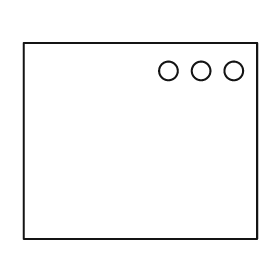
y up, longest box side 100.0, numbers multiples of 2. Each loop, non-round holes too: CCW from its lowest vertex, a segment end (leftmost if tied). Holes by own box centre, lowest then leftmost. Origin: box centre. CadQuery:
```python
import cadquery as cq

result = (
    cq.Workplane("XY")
    .moveTo(-50.0, -42.0)
    .lineTo(50.0, -42.0)
    .lineTo(50.0, 42.0)
    .lineTo(-50.0, 42.0)
    .close()
    .moveTo(12.0, 30.0)
    .circle(4.0)
    .moveTo(26.0, 30.0)
    .circle(4.0)
    .moveTo(40.0, 30.0)
    .circle(4.0)
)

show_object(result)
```